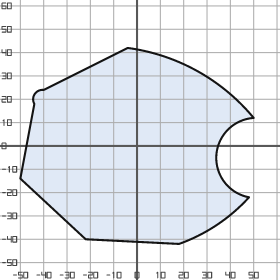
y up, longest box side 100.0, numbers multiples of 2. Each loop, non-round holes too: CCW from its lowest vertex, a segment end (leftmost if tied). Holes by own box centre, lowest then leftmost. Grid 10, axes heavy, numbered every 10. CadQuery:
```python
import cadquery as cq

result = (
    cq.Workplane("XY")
    .moveTo(18.0, -42.0)
    .threePointArc((34.0, -34.0), (48.0, -22.0))
    .threePointArc((34.0, -4.0), (50.0, 12.0))
    .threePointArc((26.0, 32.0), (-4.0, 42.0))
    .lineTo(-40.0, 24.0)
    .threePointArc((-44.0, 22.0), (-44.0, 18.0))
    .lineTo(-50.0, -14.0)
    .lineTo(-22.0, -40.0)
    .close()
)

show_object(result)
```